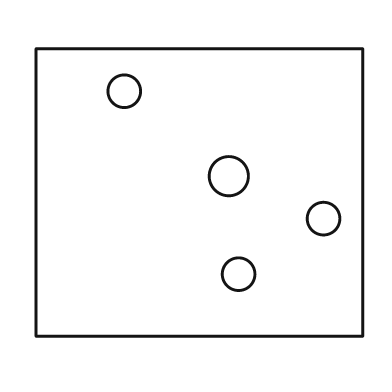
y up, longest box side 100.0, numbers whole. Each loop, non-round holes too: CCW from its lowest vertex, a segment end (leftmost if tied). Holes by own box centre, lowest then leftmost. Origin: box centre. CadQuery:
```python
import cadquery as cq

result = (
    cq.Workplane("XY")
    .moveTo(-50.0, -44.0)
    .lineTo(50.0, -44.0)
    .lineTo(50.0, 44.0)
    .lineTo(-50.0, 44.0)
    .close()
    .moveTo(12.0, -25.0)
    .circle(5.0)
    .moveTo(38.0, -8.0)
    .circle(5.0)
    .moveTo(9.0, 5.0)
    .circle(6.0)
    .moveTo(-23.0, 31.0)
    .circle(5.0)
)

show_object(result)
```